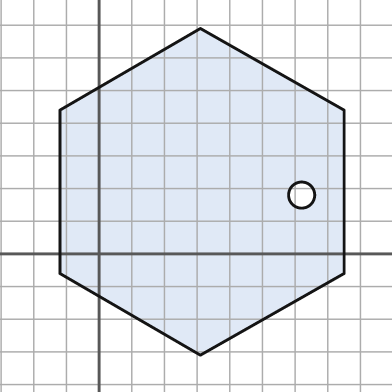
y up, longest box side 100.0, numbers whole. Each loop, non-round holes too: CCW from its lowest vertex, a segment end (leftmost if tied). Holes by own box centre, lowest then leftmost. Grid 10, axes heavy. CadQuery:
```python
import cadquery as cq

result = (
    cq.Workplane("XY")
    .moveTo(31.0, -31.0)
    .lineTo(75.0, -6.0)
    .lineTo(75.0, 44.0)
    .lineTo(31.0, 69.0)
    .lineTo(-12.0, 44.0)
    .lineTo(-12.0, -6.0)
    .close()
    .moveTo(62.0, 18.0)
    .circle(4.0)
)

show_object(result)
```